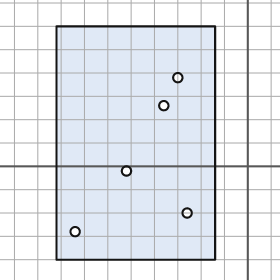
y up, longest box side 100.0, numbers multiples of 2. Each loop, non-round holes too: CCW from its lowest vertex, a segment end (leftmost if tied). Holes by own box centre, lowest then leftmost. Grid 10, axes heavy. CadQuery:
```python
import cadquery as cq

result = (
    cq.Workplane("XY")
    .moveTo(-82.0, -40.0)
    .lineTo(-14.0, -40.0)
    .lineTo(-14.0, 60.0)
    .lineTo(-82.0, 60.0)
    .close()
    .moveTo(-74.0, -28.0)
    .circle(2.0)
    .moveTo(-26.0, -20.0)
    .circle(2.0)
    .moveTo(-52.0, -2.0)
    .circle(2.0)
    .moveTo(-36.0, 26.0)
    .circle(2.0)
    .moveTo(-30.0, 38.0)
    .circle(2.0)
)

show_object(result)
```